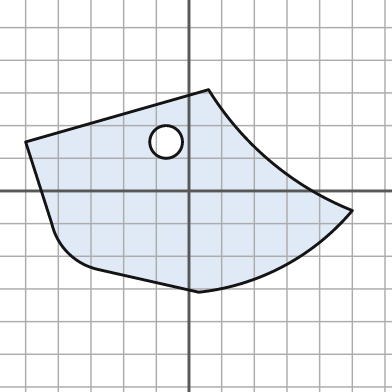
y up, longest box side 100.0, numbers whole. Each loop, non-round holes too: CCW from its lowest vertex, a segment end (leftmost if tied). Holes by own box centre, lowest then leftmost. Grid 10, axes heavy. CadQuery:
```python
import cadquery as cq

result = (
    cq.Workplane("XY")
    .moveTo(3.0, -31.0)
    .threePointArc((29.0, -23.0), (50.0, -6.0))
    .threePointArc((25.0, 9.0), (6.0, 31.0))
    .lineTo(-50.0, 15.0)
    .lineTo(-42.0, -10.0)
    .threePointArc((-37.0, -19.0), (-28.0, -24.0))
    .close()
    .moveTo(-7.0, 15.0)
    .circle(5.0)
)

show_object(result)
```